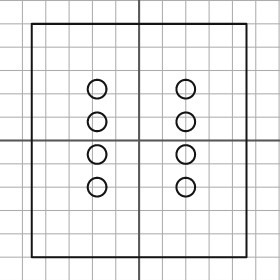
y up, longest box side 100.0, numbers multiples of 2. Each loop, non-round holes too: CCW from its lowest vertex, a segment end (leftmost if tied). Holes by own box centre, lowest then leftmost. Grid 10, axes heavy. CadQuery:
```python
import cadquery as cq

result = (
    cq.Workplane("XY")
    .moveTo(-46.0, -50.0)
    .lineTo(46.0, -50.0)
    .lineTo(46.0, 50.0)
    .lineTo(-46.0, 50.0)
    .close()
    .moveTo(-18.0, -20.0)
    .circle(4.0)
    .moveTo(20.0, -20.0)
    .circle(4.0)
    .moveTo(-18.0, -6.0)
    .circle(4.0)
    .moveTo(20.0, -6.0)
    .circle(4.0)
    .moveTo(-18.0, 8.0)
    .circle(4.0)
    .moveTo(20.0, 8.0)
    .circle(4.0)
    .moveTo(-18.0, 22.0)
    .circle(4.0)
    .moveTo(20.0, 22.0)
    .circle(4.0)
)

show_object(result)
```